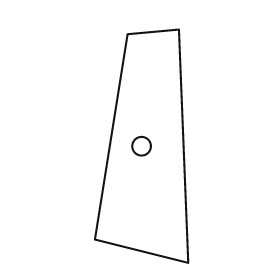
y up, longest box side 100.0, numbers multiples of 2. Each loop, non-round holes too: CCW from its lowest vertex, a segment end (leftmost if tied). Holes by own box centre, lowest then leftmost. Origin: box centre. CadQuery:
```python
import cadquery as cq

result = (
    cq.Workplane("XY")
    .moveTo(20.0, -50.0)
    .lineTo(16.0, 50.0)
    .lineTo(-6.0, 48.0)
    .lineTo(-20.0, -40.0)
    .close()
    .moveTo(0.0, 0.0)
    .circle(4.0)
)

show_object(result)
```